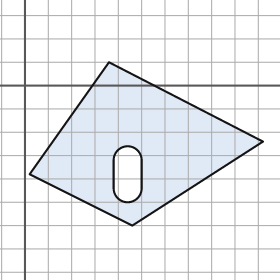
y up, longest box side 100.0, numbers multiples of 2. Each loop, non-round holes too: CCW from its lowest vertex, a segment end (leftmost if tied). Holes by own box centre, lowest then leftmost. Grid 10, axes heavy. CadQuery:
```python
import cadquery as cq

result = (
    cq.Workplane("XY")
    .moveTo(46.0, -60.0)
    .lineTo(102.0, -24.0)
    .lineTo(36.0, 10.0)
    .lineTo(2.0, -38.0)
    .close()
    .moveTo(38.0, -44.0)
    .threePointArc((44.0, -50.0), (50.0, -44.0))
    .lineTo(50.0, -32.0)
    .threePointArc((44.0, -26.0), (38.0, -32.0))
    .close()
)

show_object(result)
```